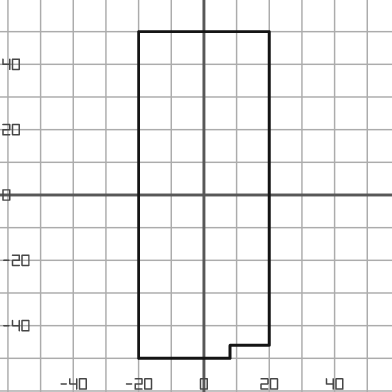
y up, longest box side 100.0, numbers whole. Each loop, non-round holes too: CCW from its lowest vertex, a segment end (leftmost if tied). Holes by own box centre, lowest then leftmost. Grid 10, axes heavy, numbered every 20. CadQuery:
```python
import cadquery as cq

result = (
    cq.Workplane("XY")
    .moveTo(-20.0, -50.0)
    .lineTo(8.0, -50.0)
    .lineTo(8.0, -46.0)
    .lineTo(20.0, -46.0)
    .lineTo(20.0, 50.0)
    .lineTo(-20.0, 50.0)
    .close()
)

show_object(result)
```